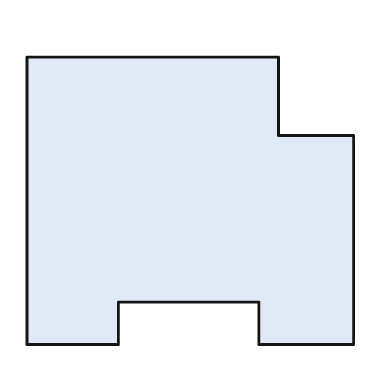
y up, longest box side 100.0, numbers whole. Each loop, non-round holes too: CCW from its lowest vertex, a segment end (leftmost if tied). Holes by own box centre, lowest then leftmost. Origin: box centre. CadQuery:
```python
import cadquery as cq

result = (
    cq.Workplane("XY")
    .moveTo(-50.0, -44.0)
    .lineTo(-22.0, -44.0)
    .lineTo(-22.0, -31.0)
    .lineTo(21.0, -31.0)
    .lineTo(21.0, -44.0)
    .lineTo(50.0, -44.0)
    .lineTo(50.0, 20.0)
    .lineTo(27.0, 20.0)
    .lineTo(27.0, 44.0)
    .lineTo(-50.0, 44.0)
    .close()
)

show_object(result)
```